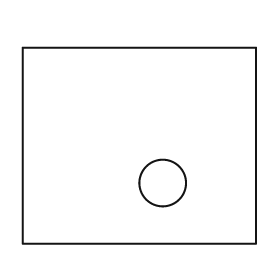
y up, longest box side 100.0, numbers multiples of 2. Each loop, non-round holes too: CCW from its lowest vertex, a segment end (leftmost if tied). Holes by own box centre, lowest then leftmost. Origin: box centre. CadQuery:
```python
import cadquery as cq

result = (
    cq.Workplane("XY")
    .moveTo(-50.0, -42.0)
    .lineTo(50.0, -42.0)
    .lineTo(50.0, 42.0)
    .lineTo(-50.0, 42.0)
    .close()
    .moveTo(10.0, -16.0)
    .circle(10.0)
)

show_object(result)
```